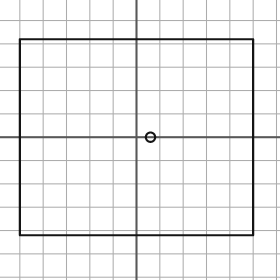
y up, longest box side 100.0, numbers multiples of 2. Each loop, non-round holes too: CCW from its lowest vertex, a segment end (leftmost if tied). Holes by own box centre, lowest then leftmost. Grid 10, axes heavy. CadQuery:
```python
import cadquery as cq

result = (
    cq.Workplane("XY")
    .moveTo(-50.0, -42.0)
    .lineTo(50.0, -42.0)
    .lineTo(50.0, 42.0)
    .lineTo(-50.0, 42.0)
    .close()
    .moveTo(6.0, 0.0)
    .circle(2.0)
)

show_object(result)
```